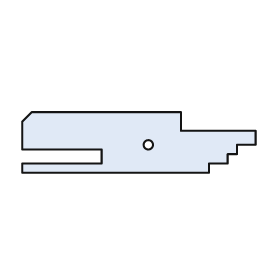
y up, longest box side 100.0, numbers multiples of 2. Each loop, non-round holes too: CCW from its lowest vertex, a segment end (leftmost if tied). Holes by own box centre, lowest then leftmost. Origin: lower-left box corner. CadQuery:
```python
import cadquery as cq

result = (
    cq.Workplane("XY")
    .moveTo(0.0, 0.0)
    .lineTo(80.0, 0.0)
    .lineTo(80.0, 4.0)
    .lineTo(88.0, 4.0)
    .lineTo(88.0, 8.0)
    .lineTo(92.0, 8.0)
    .lineTo(92.0, 12.0)
    .lineTo(100.0, 12.0)
    .lineTo(100.0, 18.0)
    .lineTo(68.0, 18.0)
    .lineTo(68.0, 26.0)
    .lineTo(4.0, 26.0)
    .lineTo(0.0, 22.0)
    .lineTo(0.0, 10.0)
    .lineTo(34.0, 10.0)
    .lineTo(34.0, 4.0)
    .lineTo(0.0, 4.0)
    .close()
    .moveTo(54.0, 12.0)
    .circle(2.0)
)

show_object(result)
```